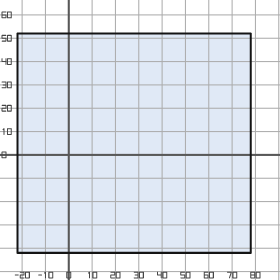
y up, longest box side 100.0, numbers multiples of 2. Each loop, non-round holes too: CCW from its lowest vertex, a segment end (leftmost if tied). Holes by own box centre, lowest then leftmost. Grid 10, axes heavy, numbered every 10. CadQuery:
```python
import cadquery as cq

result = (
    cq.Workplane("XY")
    .moveTo(-22.0, -42.0)
    .lineTo(78.0, -42.0)
    .lineTo(78.0, 52.0)
    .lineTo(-22.0, 52.0)
    .close()
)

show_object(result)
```